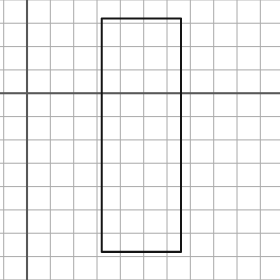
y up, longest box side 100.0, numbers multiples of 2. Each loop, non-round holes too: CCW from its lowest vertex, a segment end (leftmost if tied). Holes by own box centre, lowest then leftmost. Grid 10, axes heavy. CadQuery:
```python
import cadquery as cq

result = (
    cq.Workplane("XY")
    .moveTo(32.0, -68.0)
    .lineTo(66.0, -68.0)
    .lineTo(66.0, 32.0)
    .lineTo(32.0, 32.0)
    .close()
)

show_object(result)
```